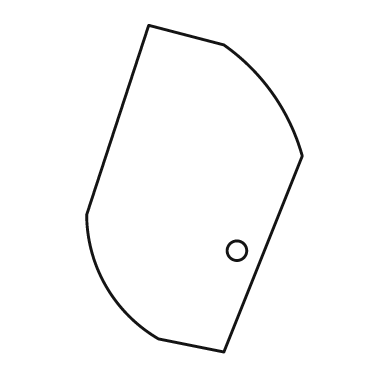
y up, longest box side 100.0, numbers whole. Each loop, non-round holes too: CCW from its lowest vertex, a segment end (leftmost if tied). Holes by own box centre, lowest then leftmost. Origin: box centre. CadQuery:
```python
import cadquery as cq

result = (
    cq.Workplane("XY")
    .moveTo(9.0, -50.0)
    .lineTo(33.0, 10.0)
    .threePointArc((24.0, 29.0), (9.0, 44.0))
    .lineTo(-14.0, 50.0)
    .lineTo(-33.0, -8.0)
    .threePointArc((-27.0, -30.0), (-11.0, -46.0))
    .close()
    .moveTo(13.0, -19.0)
    .circle(3.0)
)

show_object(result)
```